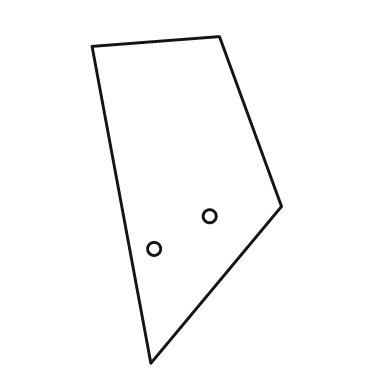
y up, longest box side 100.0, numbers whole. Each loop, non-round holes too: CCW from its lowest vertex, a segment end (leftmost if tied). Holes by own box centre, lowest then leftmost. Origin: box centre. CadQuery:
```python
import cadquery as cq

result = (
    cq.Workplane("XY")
    .moveTo(-11.0, -50.0)
    .lineTo(29.0, -2.0)
    .lineTo(10.0, 50.0)
    .lineTo(-29.0, 47.0)
    .close()
    .moveTo(-10.0, -15.0)
    .circle(2.0)
    .moveTo(7.0, -5.0)
    .circle(2.0)
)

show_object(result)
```